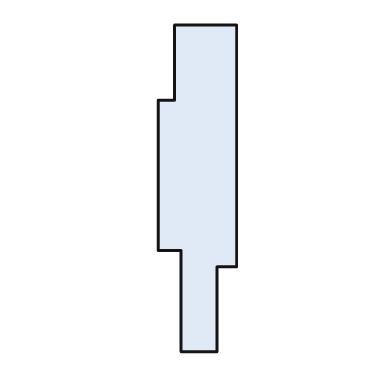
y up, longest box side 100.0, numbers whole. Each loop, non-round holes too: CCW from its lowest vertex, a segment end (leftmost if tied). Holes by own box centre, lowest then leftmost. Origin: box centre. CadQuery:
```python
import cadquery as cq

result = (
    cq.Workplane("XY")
    .moveTo(-5.0, -50.0)
    .lineTo(6.0, -50.0)
    .lineTo(6.0, -24.0)
    .lineTo(12.0, -24.0)
    .lineTo(12.0, 50.0)
    .lineTo(-7.0, 50.0)
    .lineTo(-7.0, 27.0)
    .lineTo(-12.0, 27.0)
    .lineTo(-12.0, -19.0)
    .lineTo(-5.0, -19.0)
    .close()
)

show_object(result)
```